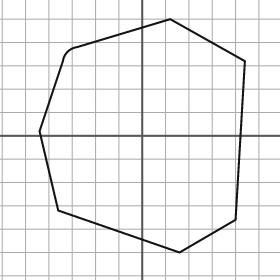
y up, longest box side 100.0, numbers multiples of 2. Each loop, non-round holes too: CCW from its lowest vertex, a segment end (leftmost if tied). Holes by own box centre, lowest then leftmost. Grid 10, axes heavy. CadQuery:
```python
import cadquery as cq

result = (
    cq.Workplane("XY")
    .moveTo(16.0, -50.0)
    .lineTo(40.0, -36.0)
    .lineTo(44.0, 32.0)
    .lineTo(12.0, 50.0)
    .lineTo(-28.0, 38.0)
    .threePointArc((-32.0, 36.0), (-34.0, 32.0))
    .lineTo(-44.0, 2.0)
    .lineTo(-36.0, -32.0)
    .close()
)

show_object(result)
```